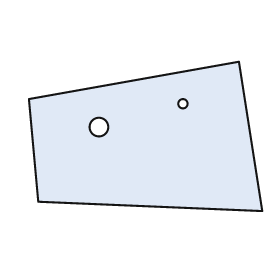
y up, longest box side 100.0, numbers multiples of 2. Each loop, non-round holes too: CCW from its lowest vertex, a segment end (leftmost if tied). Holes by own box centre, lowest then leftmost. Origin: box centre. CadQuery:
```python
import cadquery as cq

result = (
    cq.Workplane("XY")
    .moveTo(50.0, -32.0)
    .lineTo(40.0, 32.0)
    .lineTo(-50.0, 16.0)
    .lineTo(-46.0, -28.0)
    .close()
    .moveTo(-20.0, 4.0)
    .circle(4.0)
    .moveTo(16.0, 14.0)
    .circle(2.0)
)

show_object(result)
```